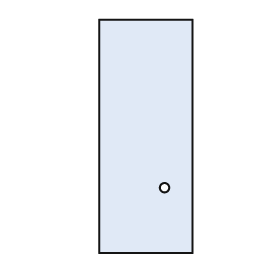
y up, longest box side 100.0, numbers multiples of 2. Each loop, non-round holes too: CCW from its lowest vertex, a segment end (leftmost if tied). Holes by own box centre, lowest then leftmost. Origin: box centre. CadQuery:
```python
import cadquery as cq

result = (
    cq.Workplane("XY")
    .moveTo(-20.0, -50.0)
    .lineTo(20.0, -50.0)
    .lineTo(20.0, 50.0)
    .lineTo(-20.0, 50.0)
    .close()
    .moveTo(8.0, -22.0)
    .circle(2.0)
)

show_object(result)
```